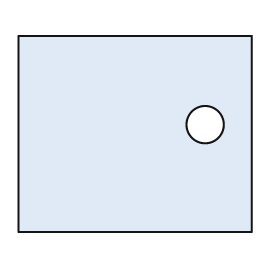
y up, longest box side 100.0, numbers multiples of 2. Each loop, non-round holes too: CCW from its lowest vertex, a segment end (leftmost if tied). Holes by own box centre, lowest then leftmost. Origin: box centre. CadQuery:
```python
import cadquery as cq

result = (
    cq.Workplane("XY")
    .moveTo(-50.0, -42.0)
    .lineTo(50.0, -42.0)
    .lineTo(50.0, 42.0)
    .lineTo(-50.0, 42.0)
    .close()
    .moveTo(30.0, 4.0)
    .circle(8.0)
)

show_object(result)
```